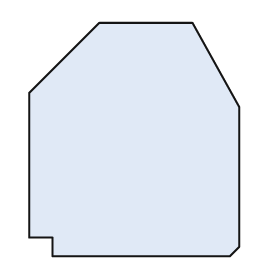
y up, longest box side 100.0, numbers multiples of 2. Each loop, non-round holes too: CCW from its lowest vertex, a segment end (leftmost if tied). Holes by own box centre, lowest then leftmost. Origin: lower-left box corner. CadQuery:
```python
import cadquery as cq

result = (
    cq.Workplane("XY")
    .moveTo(10.0, 0.0)
    .lineTo(86.0, 0.0)
    .lineTo(90.0, 4.0)
    .lineTo(90.0, 64.0)
    .lineTo(70.0, 100.0)
    .lineTo(30.0, 100.0)
    .lineTo(0.0, 70.0)
    .lineTo(0.0, 8.0)
    .lineTo(10.0, 8.0)
    .close()
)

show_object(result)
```